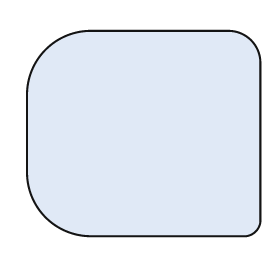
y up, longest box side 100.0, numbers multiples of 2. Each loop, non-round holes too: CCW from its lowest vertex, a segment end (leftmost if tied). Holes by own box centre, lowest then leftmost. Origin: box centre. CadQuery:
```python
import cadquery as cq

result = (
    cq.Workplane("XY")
    .moveTo(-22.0, -44.0)
    .lineTo(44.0, -44.0)
    .threePointArc((48.0, -42.0), (50.0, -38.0))
    .lineTo(50.0, 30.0)
    .threePointArc((46.0, 40.0), (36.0, 44.0))
    .lineTo(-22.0, 44.0)
    .threePointArc((-42.0, 36.0), (-50.0, 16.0))
    .lineTo(-50.0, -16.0)
    .threePointArc((-42.0, -36.0), (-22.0, -44.0))
    .close()
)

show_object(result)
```